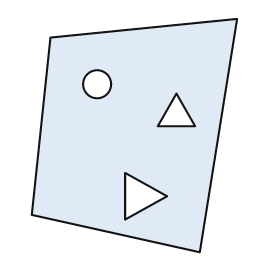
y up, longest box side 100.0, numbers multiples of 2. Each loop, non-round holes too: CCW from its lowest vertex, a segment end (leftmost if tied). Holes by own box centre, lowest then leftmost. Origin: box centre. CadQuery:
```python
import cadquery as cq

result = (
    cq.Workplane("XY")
    .moveTo(28.0, -50.0)
    .lineTo(44.0, 50.0)
    .lineTo(-36.0, 42.0)
    .lineTo(-44.0, -34.0)
    .close()
    .moveTo(-4.0, -36.0)
    .lineTo(14.0, -26.0)
    .lineTo(-4.0, -16.0)
    .close()
    .moveTo(10.0, 4.0)
    .lineTo(26.0, 4.0)
    .lineTo(18.0, 18.0)
    .close()
    .moveTo(-16.0, 22.0)
    .circle(6.0)
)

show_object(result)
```